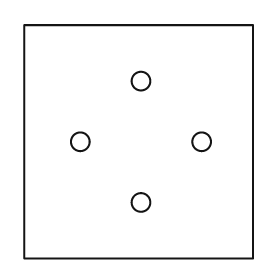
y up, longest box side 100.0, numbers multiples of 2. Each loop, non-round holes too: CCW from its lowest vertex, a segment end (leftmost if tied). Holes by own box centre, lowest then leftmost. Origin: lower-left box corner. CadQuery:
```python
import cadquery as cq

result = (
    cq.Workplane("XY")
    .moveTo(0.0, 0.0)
    .lineTo(98.0, 0.0)
    .lineTo(98.0, 100.0)
    .lineTo(0.0, 100.0)
    .close()
    .moveTo(50.0, 24.0)
    .circle(4.0)
    .moveTo(24.0, 50.0)
    .circle(4.0)
    .moveTo(76.0, 50.0)
    .circle(4.0)
    .moveTo(50.0, 76.0)
    .circle(4.0)
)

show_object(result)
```